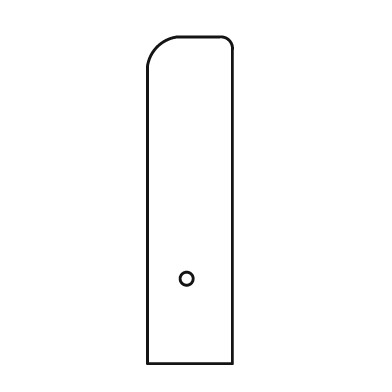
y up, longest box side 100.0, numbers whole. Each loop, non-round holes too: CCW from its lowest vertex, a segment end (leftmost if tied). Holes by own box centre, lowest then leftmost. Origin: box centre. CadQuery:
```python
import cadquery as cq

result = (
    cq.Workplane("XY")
    .moveTo(-13.0, -50.0)
    .lineTo(13.0, -50.0)
    .lineTo(13.0, 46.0)
    .threePointArc((12.0, 49.0), (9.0, 50.0))
    .lineTo(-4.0, 50.0)
    .threePointArc((-10.0, 47.0), (-13.0, 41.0))
    .close()
    .moveTo(-1.0, -24.0)
    .circle(2.0)
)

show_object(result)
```